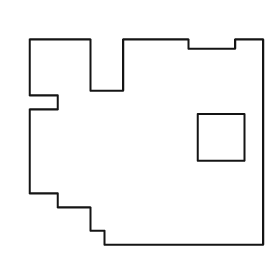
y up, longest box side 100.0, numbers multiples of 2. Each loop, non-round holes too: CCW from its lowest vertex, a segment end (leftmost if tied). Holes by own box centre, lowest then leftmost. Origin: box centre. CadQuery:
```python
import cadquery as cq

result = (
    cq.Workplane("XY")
    .moveTo(-18.0, -44.0)
    .lineTo(50.0, -44.0)
    .lineTo(50.0, 44.0)
    .lineTo(38.0, 44.0)
    .lineTo(38.0, 40.0)
    .lineTo(18.0, 40.0)
    .lineTo(18.0, 44.0)
    .lineTo(-10.0, 44.0)
    .lineTo(-10.0, 22.0)
    .lineTo(-24.0, 22.0)
    .lineTo(-24.0, 44.0)
    .lineTo(-50.0, 44.0)
    .lineTo(-50.0, 20.0)
    .lineTo(-38.0, 20.0)
    .lineTo(-38.0, 14.0)
    .lineTo(-50.0, 14.0)
    .lineTo(-50.0, -22.0)
    .lineTo(-38.0, -22.0)
    .lineTo(-38.0, -28.0)
    .lineTo(-24.0, -28.0)
    .lineTo(-24.0, -38.0)
    .lineTo(-18.0, -38.0)
    .close()
    .moveTo(22.0, -8.0)
    .lineTo(42.0, -8.0)
    .lineTo(42.0, 12.0)
    .lineTo(22.0, 12.0)
    .close()
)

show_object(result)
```